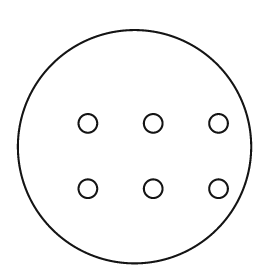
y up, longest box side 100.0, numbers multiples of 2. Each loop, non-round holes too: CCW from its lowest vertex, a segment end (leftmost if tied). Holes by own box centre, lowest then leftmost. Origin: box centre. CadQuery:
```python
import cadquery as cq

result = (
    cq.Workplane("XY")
    .moveTo(0.0, 0.0)
    .circle(50.0)
    .moveTo(-20.0, -18.0)
    .circle(4.0)
    .moveTo(8.0, -18.0)
    .circle(4.0)
    .moveTo(36.0, -18.0)
    .circle(4.0)
    .moveTo(-20.0, 10.0)
    .circle(4.0)
    .moveTo(8.0, 10.0)
    .circle(4.0)
    .moveTo(36.0, 10.0)
    .circle(4.0)
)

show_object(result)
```